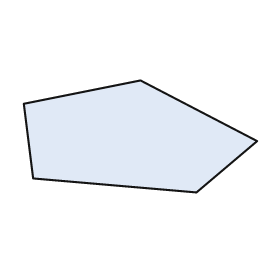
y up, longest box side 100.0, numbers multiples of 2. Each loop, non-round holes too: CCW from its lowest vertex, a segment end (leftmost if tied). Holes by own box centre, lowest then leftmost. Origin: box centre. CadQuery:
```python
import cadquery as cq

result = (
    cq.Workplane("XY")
    .moveTo(24.0, -24.0)
    .lineTo(50.0, -2.0)
    .lineTo(0.0, 24.0)
    .lineTo(-50.0, 14.0)
    .lineTo(-46.0, -18.0)
    .close()
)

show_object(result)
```